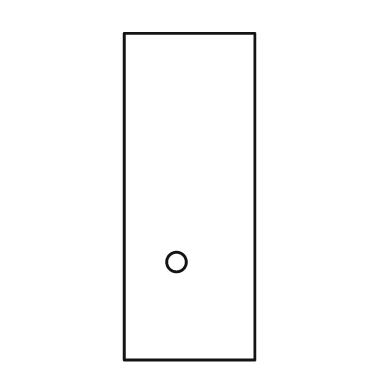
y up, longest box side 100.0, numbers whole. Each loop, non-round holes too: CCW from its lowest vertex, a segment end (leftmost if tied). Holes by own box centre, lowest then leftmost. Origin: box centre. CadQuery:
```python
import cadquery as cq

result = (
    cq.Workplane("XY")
    .moveTo(-20.0, -50.0)
    .lineTo(20.0, -50.0)
    .lineTo(20.0, 50.0)
    .lineTo(-20.0, 50.0)
    .close()
    .moveTo(-4.0, -20.0)
    .circle(3.0)
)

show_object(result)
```